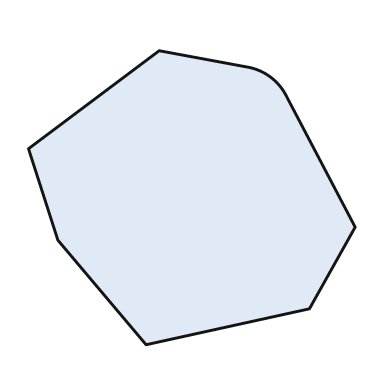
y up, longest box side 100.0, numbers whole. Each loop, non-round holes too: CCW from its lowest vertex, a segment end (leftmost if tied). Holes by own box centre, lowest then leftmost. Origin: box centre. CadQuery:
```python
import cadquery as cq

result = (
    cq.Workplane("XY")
    .moveTo(-14.0, -45.0)
    .lineTo(36.0, -34.0)
    .lineTo(50.0, -9.0)
    .lineTo(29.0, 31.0)
    .threePointArc((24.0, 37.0), (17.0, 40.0))
    .lineTo(-10.0, 45.0)
    .lineTo(-50.0, 15.0)
    .lineTo(-41.0, -13.0)
    .close()
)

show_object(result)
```